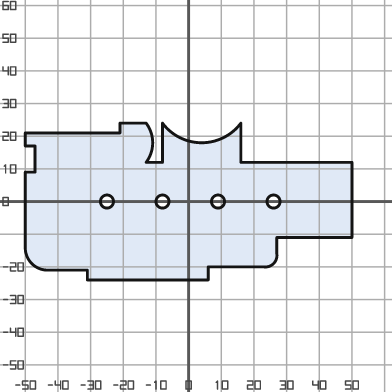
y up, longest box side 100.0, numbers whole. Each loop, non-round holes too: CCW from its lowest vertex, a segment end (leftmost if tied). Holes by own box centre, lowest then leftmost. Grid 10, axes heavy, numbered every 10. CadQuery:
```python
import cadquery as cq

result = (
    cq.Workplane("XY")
    .moveTo(-31.0, -24.0)
    .lineTo(6.0, -24.0)
    .lineTo(6.0, -20.0)
    .lineTo(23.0, -20.0)
    .threePointArc((26.0, -19.0), (27.0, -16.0))
    .lineTo(27.0, -11.0)
    .lineTo(50.0, -11.0)
    .lineTo(50.0, 12.0)
    .lineTo(16.0, 12.0)
    .lineTo(16.0, 24.0)
    .threePointArc((4.0, 18.0), (-8.0, 24.0))
    .lineTo(-8.0, 12.0)
    .lineTo(-13.0, 12.0)
    .threePointArc((-11.0, 18.0), (-13.0, 24.0))
    .lineTo(-21.0, 24.0)
    .lineTo(-21.0, 21.0)
    .lineTo(-50.0, 21.0)
    .lineTo(-50.0, 17.0)
    .lineTo(-47.0, 17.0)
    .lineTo(-47.0, 9.0)
    .lineTo(-50.0, 9.0)
    .lineTo(-50.0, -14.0)
    .threePointArc((-48.0, -19.0), (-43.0, -21.0))
    .lineTo(-31.0, -21.0)
    .close()
    .moveTo(-25.0, 0.0)
    .circle(2.0)
    .moveTo(-8.0, 0.0)
    .circle(2.0)
    .moveTo(9.0, 0.0)
    .circle(2.0)
    .moveTo(26.0, 0.0)
    .circle(2.0)
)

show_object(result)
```